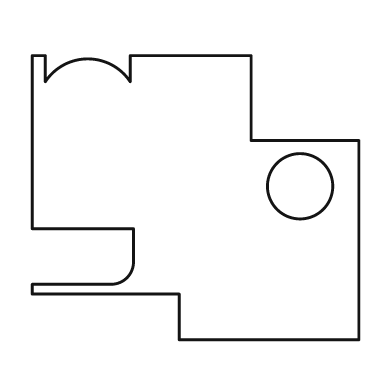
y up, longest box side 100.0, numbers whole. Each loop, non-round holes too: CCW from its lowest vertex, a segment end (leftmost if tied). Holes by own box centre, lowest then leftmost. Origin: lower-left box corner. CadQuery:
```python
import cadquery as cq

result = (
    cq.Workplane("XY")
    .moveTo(45.0, 0.0)
    .lineTo(100.0, 0.0)
    .lineTo(100.0, 61.0)
    .lineTo(67.0, 61.0)
    .lineTo(67.0, 87.0)
    .lineTo(30.0, 87.0)
    .lineTo(30.0, 79.0)
    .threePointArc((17.0, 86.0), (4.0, 79.0))
    .lineTo(4.0, 87.0)
    .lineTo(0.0, 87.0)
    .lineTo(0.0, 34.0)
    .lineTo(31.0, 34.0)
    .lineTo(31.0, 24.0)
    .threePointArc((29.0, 19.0), (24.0, 17.0))
    .lineTo(0.0, 17.0)
    .lineTo(0.0, 14.0)
    .lineTo(45.0, 14.0)
    .close()
    .moveTo(82.0, 47.0)
    .circle(10.0)
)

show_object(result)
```